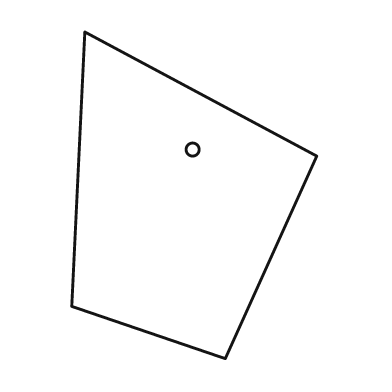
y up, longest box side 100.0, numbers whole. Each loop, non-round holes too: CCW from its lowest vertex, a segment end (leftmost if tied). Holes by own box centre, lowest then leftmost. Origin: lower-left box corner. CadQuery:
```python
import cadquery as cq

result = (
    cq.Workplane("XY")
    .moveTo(47.0, 0.0)
    .lineTo(75.0, 62.0)
    .lineTo(4.0, 100.0)
    .lineTo(0.0, 16.0)
    .close()
    .moveTo(37.0, 64.0)
    .circle(2.0)
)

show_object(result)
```